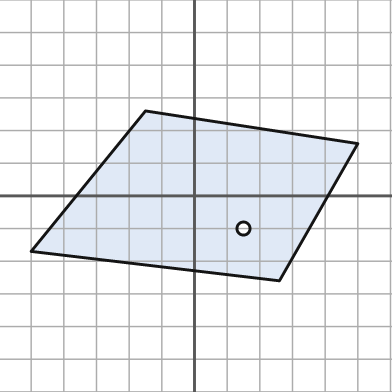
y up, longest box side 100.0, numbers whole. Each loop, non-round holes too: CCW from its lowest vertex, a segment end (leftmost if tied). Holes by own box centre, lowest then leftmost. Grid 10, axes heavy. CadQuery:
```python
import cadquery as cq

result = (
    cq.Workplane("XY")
    .moveTo(26.0, -26.0)
    .lineTo(50.0, 16.0)
    .lineTo(-15.0, 26.0)
    .lineTo(-50.0, -17.0)
    .close()
    .moveTo(15.0, -10.0)
    .circle(2.0)
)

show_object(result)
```